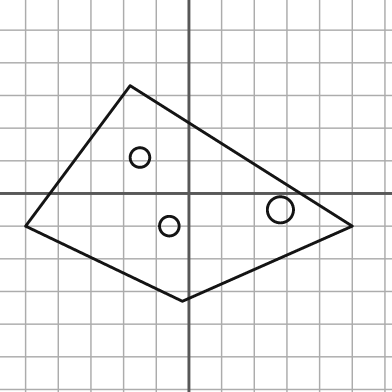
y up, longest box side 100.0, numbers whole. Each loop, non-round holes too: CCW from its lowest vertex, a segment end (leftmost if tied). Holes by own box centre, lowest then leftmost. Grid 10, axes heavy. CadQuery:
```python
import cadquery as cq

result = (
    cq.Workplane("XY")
    .moveTo(-2.0, -33.0)
    .lineTo(50.0, -10.0)
    .lineTo(-18.0, 33.0)
    .lineTo(-50.0, -10.0)
    .close()
    .moveTo(-6.0, -10.0)
    .circle(3.0)
    .moveTo(28.0, -5.0)
    .circle(4.0)
    .moveTo(-15.0, 11.0)
    .circle(3.0)
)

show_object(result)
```